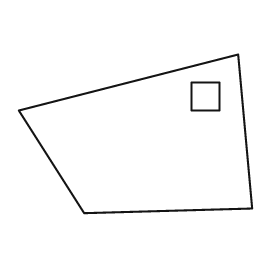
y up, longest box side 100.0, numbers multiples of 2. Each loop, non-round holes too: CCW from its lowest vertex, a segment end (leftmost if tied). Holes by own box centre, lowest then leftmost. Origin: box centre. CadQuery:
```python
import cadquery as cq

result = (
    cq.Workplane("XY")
    .moveTo(-22.0, -34.0)
    .lineTo(50.0, -32.0)
    .lineTo(44.0, 34.0)
    .lineTo(-50.0, 10.0)
    .close()
    .moveTo(24.0, 10.0)
    .lineTo(36.0, 10.0)
    .lineTo(36.0, 22.0)
    .lineTo(24.0, 22.0)
    .close()
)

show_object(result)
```